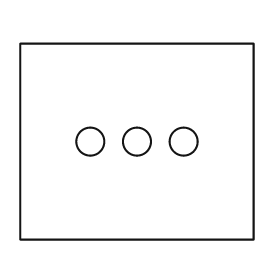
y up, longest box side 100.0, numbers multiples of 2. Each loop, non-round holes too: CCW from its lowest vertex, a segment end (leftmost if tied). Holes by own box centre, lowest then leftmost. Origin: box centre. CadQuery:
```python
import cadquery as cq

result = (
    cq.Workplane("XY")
    .moveTo(-50.0, -42.0)
    .lineTo(50.0, -42.0)
    .lineTo(50.0, 42.0)
    .lineTo(-50.0, 42.0)
    .close()
    .moveTo(-20.0, 0.0)
    .circle(6.0)
    .moveTo(0.0, 0.0)
    .circle(6.0)
    .moveTo(20.0, 0.0)
    .circle(6.0)
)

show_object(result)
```